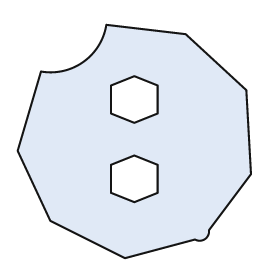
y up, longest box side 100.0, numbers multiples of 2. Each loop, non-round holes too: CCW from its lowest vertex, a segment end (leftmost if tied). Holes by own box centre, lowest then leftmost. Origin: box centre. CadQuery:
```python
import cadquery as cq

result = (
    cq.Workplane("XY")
    .moveTo(-4.0, -50.0)
    .lineTo(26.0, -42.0)
    .threePointArc((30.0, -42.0), (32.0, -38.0))
    .lineTo(50.0, -14.0)
    .lineTo(48.0, 22.0)
    .lineTo(22.0, 46.0)
    .lineTo(-12.0, 50.0)
    .threePointArc((-22.0, 34.0), (-40.0, 30.0))
    .lineTo(-50.0, -4.0)
    .lineTo(-36.0, -34.0)
    .close()
    .moveTo(0.0, -26.0)
    .lineTo(10.0, -22.0)
    .lineTo(10.0, -10.0)
    .lineTo(0.0, -6.0)
    .lineTo(-10.0, -10.0)
    .lineTo(-10.0, -22.0)
    .close()
    .moveTo(0.0, 8.0)
    .lineTo(10.0, 12.0)
    .lineTo(10.0, 24.0)
    .lineTo(0.0, 28.0)
    .lineTo(-10.0, 24.0)
    .lineTo(-10.0, 12.0)
    .close()
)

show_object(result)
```